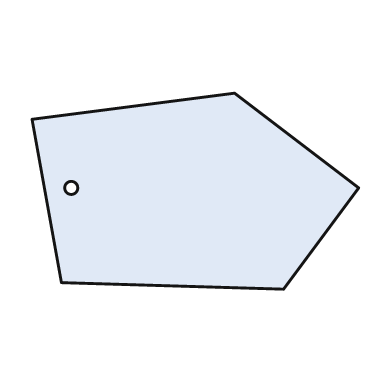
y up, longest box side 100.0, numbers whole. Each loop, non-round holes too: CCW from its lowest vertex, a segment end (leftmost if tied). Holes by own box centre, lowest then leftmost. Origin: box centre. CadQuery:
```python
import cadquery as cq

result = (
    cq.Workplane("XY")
    .moveTo(27.0, -30.0)
    .lineTo(50.0, 1.0)
    .lineTo(12.0, 30.0)
    .lineTo(-50.0, 22.0)
    .lineTo(-41.0, -28.0)
    .close()
    .moveTo(-38.0, 1.0)
    .circle(2.0)
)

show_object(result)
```